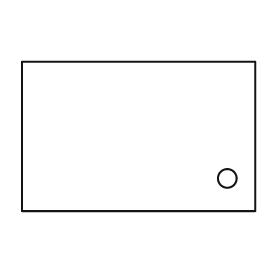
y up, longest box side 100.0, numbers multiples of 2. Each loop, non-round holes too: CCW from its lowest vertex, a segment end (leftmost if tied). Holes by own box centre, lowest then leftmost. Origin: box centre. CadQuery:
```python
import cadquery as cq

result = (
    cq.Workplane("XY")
    .moveTo(-50.0, -32.0)
    .lineTo(50.0, -32.0)
    .lineTo(50.0, 32.0)
    .lineTo(-50.0, 32.0)
    .close()
    .moveTo(38.0, -18.0)
    .circle(4.0)
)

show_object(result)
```